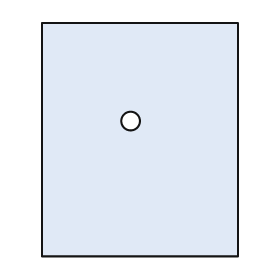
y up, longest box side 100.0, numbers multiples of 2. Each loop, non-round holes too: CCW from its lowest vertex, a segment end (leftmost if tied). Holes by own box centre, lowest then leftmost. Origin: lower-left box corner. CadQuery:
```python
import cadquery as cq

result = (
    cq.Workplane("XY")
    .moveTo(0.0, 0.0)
    .lineTo(84.0, 0.0)
    .lineTo(84.0, 100.0)
    .lineTo(0.0, 100.0)
    .close()
    .moveTo(38.0, 58.0)
    .circle(4.0)
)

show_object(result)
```